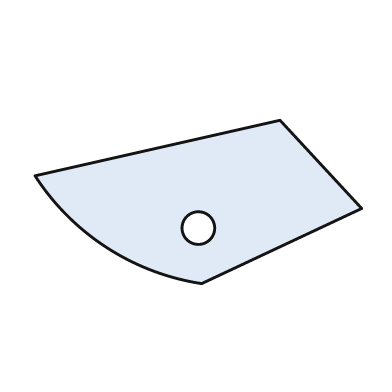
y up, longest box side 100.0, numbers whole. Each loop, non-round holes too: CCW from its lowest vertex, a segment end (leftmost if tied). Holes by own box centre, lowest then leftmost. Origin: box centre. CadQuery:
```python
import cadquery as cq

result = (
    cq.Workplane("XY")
    .moveTo(1.0, -25.0)
    .lineTo(50.0, -2.0)
    .lineTo(25.0, 25.0)
    .lineTo(-50.0, 8.0)
    .threePointArc((-28.0, -14.0), (1.0, -25.0))
    .close()
    .moveTo(0.0, -8.0)
    .circle(5.0)
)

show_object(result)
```